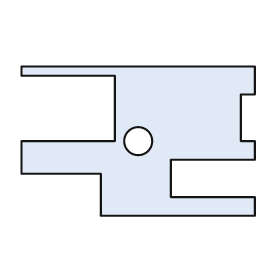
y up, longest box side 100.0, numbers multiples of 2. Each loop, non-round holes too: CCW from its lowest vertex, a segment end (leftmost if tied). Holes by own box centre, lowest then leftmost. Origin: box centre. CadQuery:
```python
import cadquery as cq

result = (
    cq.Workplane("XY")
    .moveTo(-16.0, -32.0)
    .lineTo(50.0, -32.0)
    .lineTo(50.0, -24.0)
    .lineTo(14.0, -24.0)
    .lineTo(14.0, -8.0)
    .lineTo(50.0, -8.0)
    .lineTo(50.0, 0.0)
    .lineTo(44.0, 0.0)
    .lineTo(44.0, 20.0)
    .lineTo(50.0, 20.0)
    .lineTo(50.0, 32.0)
    .lineTo(-50.0, 32.0)
    .lineTo(-50.0, 28.0)
    .lineTo(-10.0, 28.0)
    .lineTo(-10.0, 0.0)
    .lineTo(-50.0, 0.0)
    .lineTo(-50.0, -14.0)
    .lineTo(-16.0, -14.0)
    .close()
    .moveTo(0.0, 0.0)
    .circle(6.0)
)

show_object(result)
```